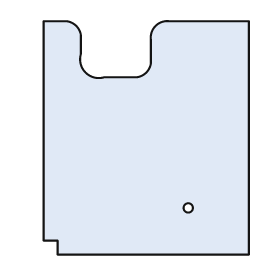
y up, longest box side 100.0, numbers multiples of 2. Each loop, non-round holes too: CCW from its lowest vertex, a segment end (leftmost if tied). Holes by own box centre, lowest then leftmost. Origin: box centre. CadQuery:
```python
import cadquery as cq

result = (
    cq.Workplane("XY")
    .moveTo(-38.0, -50.0)
    .lineTo(44.0, -50.0)
    .lineTo(44.0, 50.0)
    .lineTo(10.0, 50.0)
    .threePointArc((4.0, 48.0), (2.0, 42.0))
    .lineTo(2.0, 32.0)
    .threePointArc((0.0, 28.0), (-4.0, 26.0))
    .lineTo(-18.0, 26.0)
    .threePointArc((-26.0, 28.0), (-28.0, 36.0))
    .lineTo(-28.0, 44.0)
    .threePointArc((-30.0, 48.0), (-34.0, 50.0))
    .lineTo(-44.0, 50.0)
    .lineTo(-44.0, -44.0)
    .lineTo(-38.0, -44.0)
    .close()
    .moveTo(18.0, -30.0)
    .circle(2.0)
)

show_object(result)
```